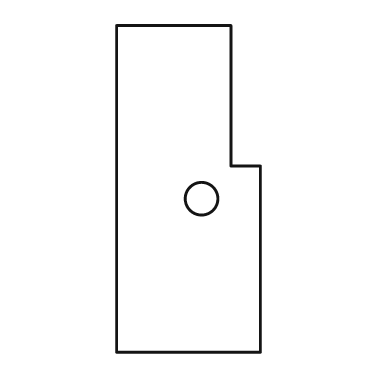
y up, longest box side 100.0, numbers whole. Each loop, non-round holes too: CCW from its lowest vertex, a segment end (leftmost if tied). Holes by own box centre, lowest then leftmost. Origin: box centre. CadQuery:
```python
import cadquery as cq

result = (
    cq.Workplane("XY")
    .moveTo(-22.0, -50.0)
    .lineTo(22.0, -50.0)
    .lineTo(22.0, 7.0)
    .lineTo(13.0, 7.0)
    .lineTo(13.0, 50.0)
    .lineTo(-22.0, 50.0)
    .close()
    .moveTo(4.0, -3.0)
    .circle(5.0)
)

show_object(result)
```